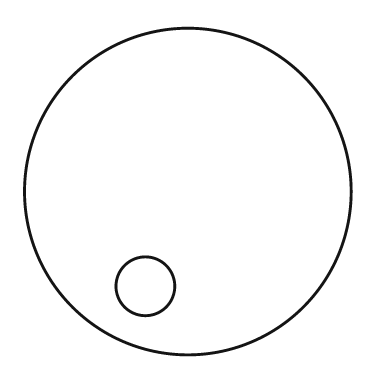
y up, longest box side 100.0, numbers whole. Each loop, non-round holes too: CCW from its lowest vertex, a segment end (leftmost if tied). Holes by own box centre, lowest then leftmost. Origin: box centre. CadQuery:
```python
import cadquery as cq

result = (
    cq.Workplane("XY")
    .moveTo(0.0, 0.0)
    .circle(50.0)
    .moveTo(-13.0, -29.0)
    .circle(9.0)
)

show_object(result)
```